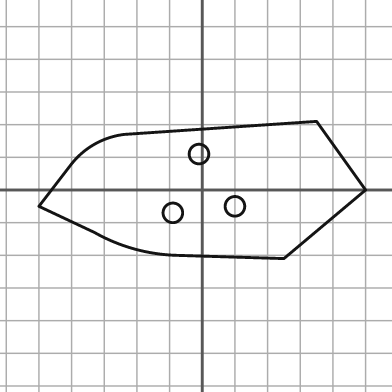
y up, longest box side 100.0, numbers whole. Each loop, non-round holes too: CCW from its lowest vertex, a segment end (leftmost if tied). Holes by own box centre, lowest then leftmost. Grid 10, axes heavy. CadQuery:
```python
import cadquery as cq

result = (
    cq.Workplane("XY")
    .moveTo(25.0, -21.0)
    .lineTo(50.0, 0.0)
    .lineTo(35.0, 21.0)
    .lineTo(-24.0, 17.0)
    .threePointArc((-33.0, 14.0), (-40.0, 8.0))
    .lineTo(-50.0, -5.0)
    .lineTo(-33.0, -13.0)
    .threePointArc((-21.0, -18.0), (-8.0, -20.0))
    .close()
    .moveTo(-9.0, -7.0)
    .circle(3.0)
    .moveTo(10.0, -5.0)
    .circle(3.0)
    .moveTo(-1.0, 11.0)
    .circle(3.0)
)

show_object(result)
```